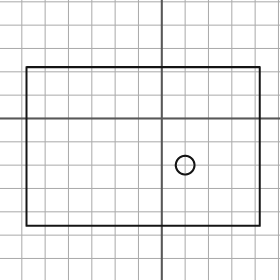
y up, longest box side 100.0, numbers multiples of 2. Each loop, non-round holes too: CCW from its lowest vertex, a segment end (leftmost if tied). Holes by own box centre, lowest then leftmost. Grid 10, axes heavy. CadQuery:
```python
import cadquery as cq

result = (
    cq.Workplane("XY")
    .moveTo(-58.0, -46.0)
    .lineTo(42.0, -46.0)
    .lineTo(42.0, 22.0)
    .lineTo(-58.0, 22.0)
    .close()
    .moveTo(10.0, -20.0)
    .circle(4.0)
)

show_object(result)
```